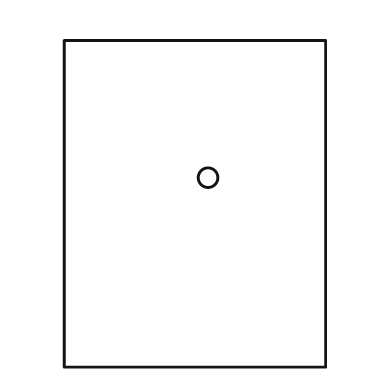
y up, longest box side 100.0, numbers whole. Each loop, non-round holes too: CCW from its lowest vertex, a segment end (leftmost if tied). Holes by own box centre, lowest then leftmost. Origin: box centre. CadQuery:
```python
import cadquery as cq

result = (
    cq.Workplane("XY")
    .moveTo(-40.0, -50.0)
    .lineTo(40.0, -50.0)
    .lineTo(40.0, 50.0)
    .lineTo(-40.0, 50.0)
    .close()
    .moveTo(4.0, 8.0)
    .circle(3.0)
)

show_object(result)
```